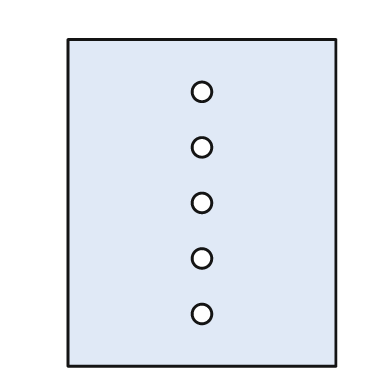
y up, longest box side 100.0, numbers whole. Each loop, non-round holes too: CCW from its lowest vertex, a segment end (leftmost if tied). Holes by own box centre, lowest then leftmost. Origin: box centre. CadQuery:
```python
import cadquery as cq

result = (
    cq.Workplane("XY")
    .moveTo(-41.0, -50.0)
    .lineTo(41.0, -50.0)
    .lineTo(41.0, 50.0)
    .lineTo(-41.0, 50.0)
    .close()
    .moveTo(0.0, -34.0)
    .circle(3.0)
    .moveTo(0.0, -17.0)
    .circle(3.0)
    .moveTo(0.0, 0.0)
    .circle(3.0)
    .moveTo(0.0, 17.0)
    .circle(3.0)
    .moveTo(0.0, 34.0)
    .circle(3.0)
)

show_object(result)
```